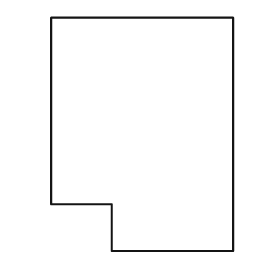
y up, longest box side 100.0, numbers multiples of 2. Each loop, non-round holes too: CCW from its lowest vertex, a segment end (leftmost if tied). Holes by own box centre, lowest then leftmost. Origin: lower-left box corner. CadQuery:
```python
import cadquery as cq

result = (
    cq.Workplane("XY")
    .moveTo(26.0, 0.0)
    .lineTo(78.0, 0.0)
    .lineTo(78.0, 100.0)
    .lineTo(0.0, 100.0)
    .lineTo(0.0, 20.0)
    .lineTo(26.0, 20.0)
    .close()
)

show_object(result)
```